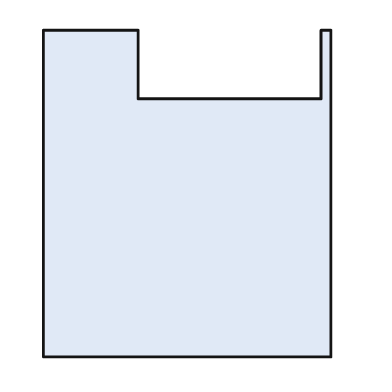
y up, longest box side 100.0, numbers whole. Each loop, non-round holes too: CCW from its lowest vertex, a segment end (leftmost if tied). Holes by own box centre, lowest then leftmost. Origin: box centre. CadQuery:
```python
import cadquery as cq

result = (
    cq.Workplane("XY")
    .moveTo(-44.0, -50.0)
    .lineTo(44.0, -50.0)
    .lineTo(44.0, 50.0)
    .lineTo(41.0, 50.0)
    .lineTo(41.0, 29.0)
    .lineTo(-15.0, 29.0)
    .lineTo(-15.0, 50.0)
    .lineTo(-44.0, 50.0)
    .close()
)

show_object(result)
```